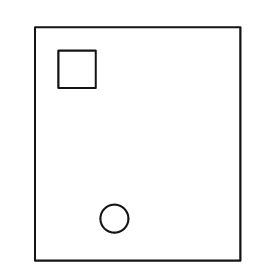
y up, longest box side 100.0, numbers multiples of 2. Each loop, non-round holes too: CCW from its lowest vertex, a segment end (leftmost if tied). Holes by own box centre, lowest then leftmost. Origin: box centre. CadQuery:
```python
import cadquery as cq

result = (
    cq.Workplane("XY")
    .moveTo(-44.0, -50.0)
    .lineTo(44.0, -50.0)
    .lineTo(44.0, 50.0)
    .lineTo(-44.0, 50.0)
    .close()
    .moveTo(-10.0, -32.0)
    .circle(6.0)
    .moveTo(-34.0, 24.0)
    .lineTo(-18.0, 24.0)
    .lineTo(-18.0, 40.0)
    .lineTo(-34.0, 40.0)
    .close()
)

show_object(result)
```